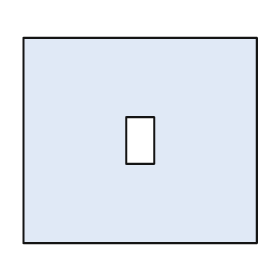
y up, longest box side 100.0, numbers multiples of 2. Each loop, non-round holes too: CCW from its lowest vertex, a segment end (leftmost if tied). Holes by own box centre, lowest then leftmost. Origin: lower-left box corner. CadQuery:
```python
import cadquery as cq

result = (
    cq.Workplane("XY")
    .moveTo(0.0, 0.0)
    .lineTo(100.0, 0.0)
    .lineTo(100.0, 88.0)
    .lineTo(0.0, 88.0)
    .close()
    .moveTo(44.0, 34.0)
    .lineTo(56.0, 34.0)
    .lineTo(56.0, 54.0)
    .lineTo(44.0, 54.0)
    .close()
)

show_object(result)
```